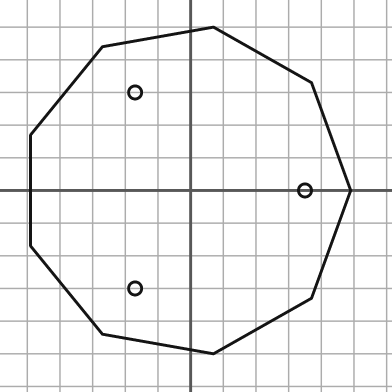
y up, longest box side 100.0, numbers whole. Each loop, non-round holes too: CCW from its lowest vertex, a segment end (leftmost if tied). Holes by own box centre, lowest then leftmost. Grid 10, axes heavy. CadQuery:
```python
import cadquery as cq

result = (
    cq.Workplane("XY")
    .moveTo(7.0, -50.0)
    .lineTo(37.0, -33.0)
    .lineTo(49.0, 0.0)
    .lineTo(37.0, 33.0)
    .lineTo(7.0, 50.0)
    .lineTo(-27.0, 44.0)
    .lineTo(-49.0, 17.0)
    .lineTo(-49.0, -17.0)
    .lineTo(-27.0, -44.0)
    .close()
    .moveTo(-17.0, -30.0)
    .circle(2.0)
    .moveTo(35.0, 0.0)
    .circle(2.0)
    .moveTo(-17.0, 30.0)
    .circle(2.0)
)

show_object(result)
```